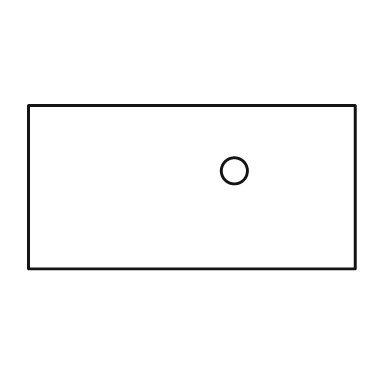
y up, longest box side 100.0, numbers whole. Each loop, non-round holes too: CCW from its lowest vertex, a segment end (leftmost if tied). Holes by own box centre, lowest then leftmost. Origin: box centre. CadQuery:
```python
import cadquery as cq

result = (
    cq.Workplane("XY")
    .moveTo(-50.0, -25.0)
    .lineTo(50.0, -25.0)
    .lineTo(50.0, 25.0)
    .lineTo(-50.0, 25.0)
    .close()
    .moveTo(13.0, 5.0)
    .circle(4.0)
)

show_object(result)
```